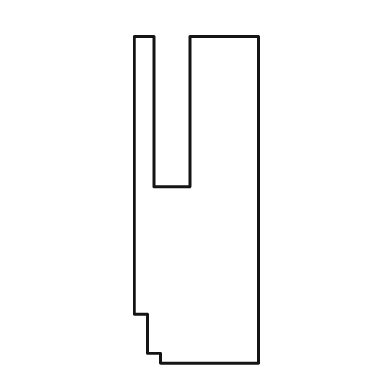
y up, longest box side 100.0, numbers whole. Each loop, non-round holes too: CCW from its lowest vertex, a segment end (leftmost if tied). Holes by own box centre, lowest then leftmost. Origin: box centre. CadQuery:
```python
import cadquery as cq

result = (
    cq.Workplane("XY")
    .moveTo(-11.0, -50.0)
    .lineTo(19.0, -50.0)
    .lineTo(19.0, 50.0)
    .lineTo(-2.0, 50.0)
    .lineTo(-2.0, 4.0)
    .lineTo(-13.0, 4.0)
    .lineTo(-13.0, 50.0)
    .lineTo(-19.0, 50.0)
    .lineTo(-19.0, -35.0)
    .lineTo(-15.0, -35.0)
    .lineTo(-15.0, -47.0)
    .lineTo(-11.0, -47.0)
    .close()
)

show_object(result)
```